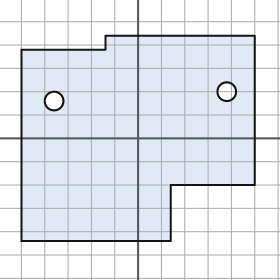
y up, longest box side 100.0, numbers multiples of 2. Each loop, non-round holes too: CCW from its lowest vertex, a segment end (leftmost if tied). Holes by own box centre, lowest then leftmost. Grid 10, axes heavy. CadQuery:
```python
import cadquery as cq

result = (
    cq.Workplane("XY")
    .moveTo(-50.0, -44.0)
    .lineTo(14.0, -44.0)
    .lineTo(14.0, -20.0)
    .lineTo(50.0, -20.0)
    .lineTo(50.0, 44.0)
    .lineTo(-14.0, 44.0)
    .lineTo(-14.0, 38.0)
    .lineTo(-50.0, 38.0)
    .close()
    .moveTo(-36.0, 16.0)
    .circle(4.0)
    .moveTo(38.0, 20.0)
    .circle(4.0)
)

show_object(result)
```